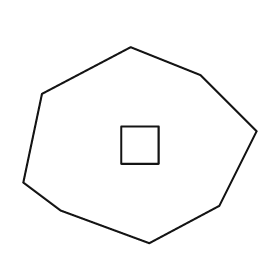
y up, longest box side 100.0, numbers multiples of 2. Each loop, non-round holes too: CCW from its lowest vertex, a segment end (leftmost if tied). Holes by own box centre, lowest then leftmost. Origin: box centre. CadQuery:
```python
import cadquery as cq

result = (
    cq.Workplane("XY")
    .moveTo(4.0, -42.0)
    .lineTo(34.0, -26.0)
    .lineTo(50.0, 6.0)
    .lineTo(26.0, 30.0)
    .lineTo(-4.0, 42.0)
    .lineTo(-42.0, 22.0)
    .lineTo(-50.0, -16.0)
    .lineTo(-34.0, -28.0)
    .close()
    .moveTo(-8.0, -8.0)
    .lineTo(8.0, -8.0)
    .lineTo(8.0, 8.0)
    .lineTo(-8.0, 8.0)
    .close()
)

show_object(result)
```